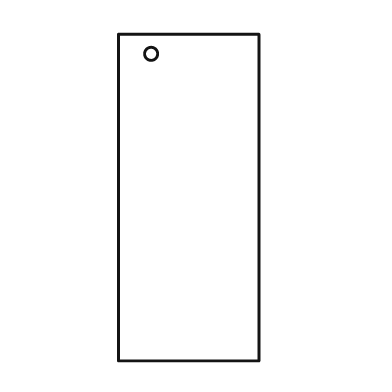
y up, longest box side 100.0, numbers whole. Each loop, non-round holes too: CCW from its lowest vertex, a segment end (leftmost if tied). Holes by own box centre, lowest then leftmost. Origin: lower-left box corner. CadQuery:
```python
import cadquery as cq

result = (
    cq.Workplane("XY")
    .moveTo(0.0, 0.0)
    .lineTo(43.0, 0.0)
    .lineTo(43.0, 100.0)
    .lineTo(0.0, 100.0)
    .close()
    .moveTo(10.0, 94.0)
    .circle(2.0)
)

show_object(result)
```